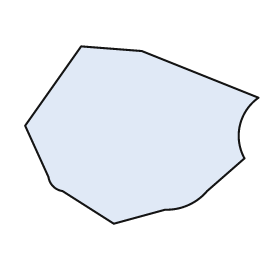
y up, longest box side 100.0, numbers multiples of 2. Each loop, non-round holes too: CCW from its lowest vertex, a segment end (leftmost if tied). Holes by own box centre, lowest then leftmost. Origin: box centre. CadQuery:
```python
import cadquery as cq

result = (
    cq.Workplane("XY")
    .moveTo(-12.0, -38.0)
    .lineTo(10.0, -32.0)
    .threePointArc((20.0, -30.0), (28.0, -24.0))
    .lineTo(44.0, -10.0)
    .threePointArc((42.0, 4.0), (50.0, 16.0))
    .lineTo(0.0, 36.0)
    .lineTo(-26.0, 38.0)
    .lineTo(-50.0, 4.0)
    .lineTo(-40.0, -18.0)
    .threePointArc((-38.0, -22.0), (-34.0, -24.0))
    .close()
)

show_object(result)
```